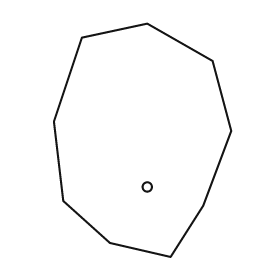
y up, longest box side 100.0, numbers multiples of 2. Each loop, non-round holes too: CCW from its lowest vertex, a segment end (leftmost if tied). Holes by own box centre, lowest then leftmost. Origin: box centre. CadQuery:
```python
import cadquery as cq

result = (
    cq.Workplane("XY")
    .moveTo(12.0, -50.0)
    .lineTo(26.0, -28.0)
    .lineTo(38.0, 4.0)
    .lineTo(30.0, 34.0)
    .lineTo(2.0, 50.0)
    .lineTo(-26.0, 44.0)
    .lineTo(-38.0, 8.0)
    .lineTo(-34.0, -26.0)
    .lineTo(-14.0, -44.0)
    .close()
    .moveTo(2.0, -20.0)
    .circle(2.0)
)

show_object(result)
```